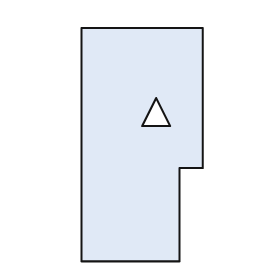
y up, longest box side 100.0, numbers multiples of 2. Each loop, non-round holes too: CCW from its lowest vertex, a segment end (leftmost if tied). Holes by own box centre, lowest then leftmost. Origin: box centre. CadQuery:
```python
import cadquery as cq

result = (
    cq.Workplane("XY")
    .moveTo(-26.0, -50.0)
    .lineTo(16.0, -50.0)
    .lineTo(16.0, -10.0)
    .lineTo(26.0, -10.0)
    .lineTo(26.0, 50.0)
    .lineTo(-26.0, 50.0)
    .close()
    .moveTo(0.0, 8.0)
    .lineTo(12.0, 8.0)
    .lineTo(6.0, 20.0)
    .close()
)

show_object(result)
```